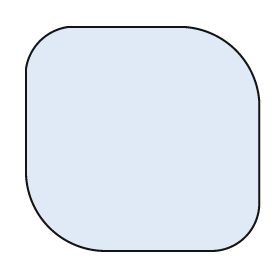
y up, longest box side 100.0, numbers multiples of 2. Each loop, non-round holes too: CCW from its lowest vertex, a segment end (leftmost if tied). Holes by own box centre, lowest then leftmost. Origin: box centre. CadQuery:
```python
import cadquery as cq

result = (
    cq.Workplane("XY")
    .moveTo(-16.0, -48.0)
    .lineTo(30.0, -48.0)
    .threePointArc((44.0, -42.0), (50.0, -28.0))
    .lineTo(50.0, 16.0)
    .threePointArc((40.0, 38.0), (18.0, 48.0))
    .lineTo(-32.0, 48.0)
    .threePointArc((-44.0, 42.0), (-50.0, 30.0))
    .lineTo(-50.0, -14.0)
    .threePointArc((-40.0, -38.0), (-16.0, -48.0))
    .close()
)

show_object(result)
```